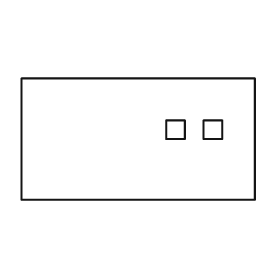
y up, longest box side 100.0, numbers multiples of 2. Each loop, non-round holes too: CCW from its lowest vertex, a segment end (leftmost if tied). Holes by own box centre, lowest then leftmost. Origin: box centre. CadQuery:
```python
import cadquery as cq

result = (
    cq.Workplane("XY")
    .moveTo(-50.0, -26.0)
    .lineTo(50.0, -26.0)
    .lineTo(50.0, 26.0)
    .lineTo(-50.0, 26.0)
    .close()
    .moveTo(12.0, 0.0)
    .lineTo(20.0, 0.0)
    .lineTo(20.0, 8.0)
    .lineTo(12.0, 8.0)
    .close()
    .moveTo(28.0, 0.0)
    .lineTo(36.0, 0.0)
    .lineTo(36.0, 8.0)
    .lineTo(28.0, 8.0)
    .close()
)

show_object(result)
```